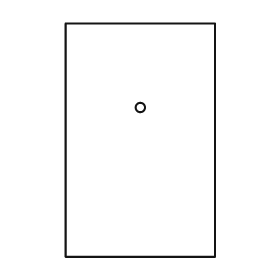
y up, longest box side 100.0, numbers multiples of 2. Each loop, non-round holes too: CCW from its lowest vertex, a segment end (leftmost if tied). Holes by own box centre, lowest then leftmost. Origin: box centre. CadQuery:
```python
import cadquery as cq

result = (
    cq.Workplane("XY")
    .moveTo(-32.0, -50.0)
    .lineTo(32.0, -50.0)
    .lineTo(32.0, 50.0)
    .lineTo(-32.0, 50.0)
    .close()
    .moveTo(0.0, 14.0)
    .circle(2.0)
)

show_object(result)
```